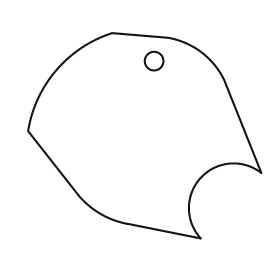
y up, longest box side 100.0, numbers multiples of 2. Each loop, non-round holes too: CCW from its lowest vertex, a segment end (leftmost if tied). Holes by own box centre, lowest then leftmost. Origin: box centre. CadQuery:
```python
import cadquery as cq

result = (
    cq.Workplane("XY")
    .moveTo(24.0, -44.0)
    .threePointArc((24.0, -18.0), (50.0, -16.0))
    .lineTo(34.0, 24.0)
    .threePointArc((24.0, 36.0), (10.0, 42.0))
    .lineTo(-14.0, 44.0)
    .threePointArc((-38.0, 28.0), (-50.0, 2.0))
    .lineTo(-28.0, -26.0)
    .threePointArc((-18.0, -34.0), (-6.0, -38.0))
    .close()
    .moveTo(4.0, 32.0)
    .circle(4.0)
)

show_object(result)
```